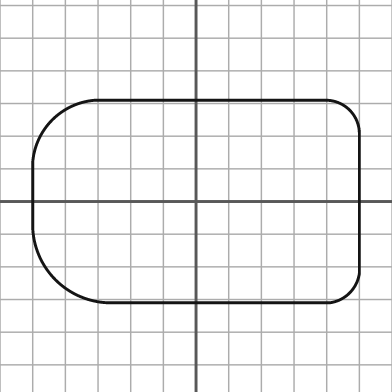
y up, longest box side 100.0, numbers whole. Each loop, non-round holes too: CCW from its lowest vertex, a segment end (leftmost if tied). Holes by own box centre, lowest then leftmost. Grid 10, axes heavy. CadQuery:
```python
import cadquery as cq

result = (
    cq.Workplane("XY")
    .moveTo(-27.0, -31.0)
    .lineTo(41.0, -31.0)
    .threePointArc((47.0, -28.0), (50.0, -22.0))
    .lineTo(50.0, 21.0)
    .threePointArc((47.0, 28.0), (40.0, 31.0))
    .lineTo(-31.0, 31.0)
    .threePointArc((-44.0, 25.0), (-50.0, 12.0))
    .lineTo(-50.0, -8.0)
    .threePointArc((-43.0, -24.0), (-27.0, -31.0))
    .close()
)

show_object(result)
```